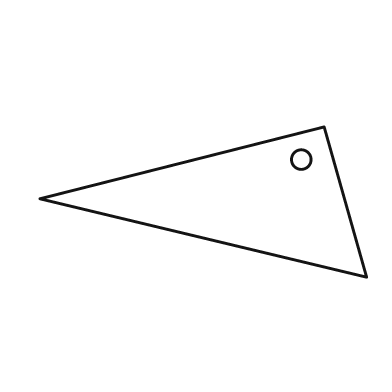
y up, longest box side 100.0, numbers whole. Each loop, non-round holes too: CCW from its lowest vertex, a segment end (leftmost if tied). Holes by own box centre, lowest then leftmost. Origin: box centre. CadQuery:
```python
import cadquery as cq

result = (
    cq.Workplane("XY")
    .moveTo(50.0, -23.0)
    .lineTo(37.0, 23.0)
    .lineTo(-50.0, 1.0)
    .close()
    .moveTo(30.0, 13.0)
    .circle(3.0)
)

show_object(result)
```